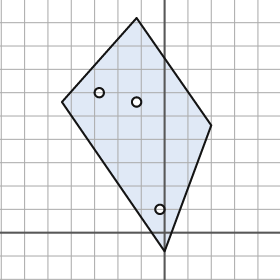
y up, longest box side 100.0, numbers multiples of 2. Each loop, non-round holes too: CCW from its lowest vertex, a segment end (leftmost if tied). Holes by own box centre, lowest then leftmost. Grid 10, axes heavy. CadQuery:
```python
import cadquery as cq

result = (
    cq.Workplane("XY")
    .moveTo(0.0, -8.0)
    .lineTo(20.0, 46.0)
    .lineTo(-12.0, 92.0)
    .lineTo(-44.0, 56.0)
    .close()
    .moveTo(-2.0, 10.0)
    .circle(2.0)
    .moveTo(-12.0, 56.0)
    .circle(2.0)
    .moveTo(-28.0, 60.0)
    .circle(2.0)
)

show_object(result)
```